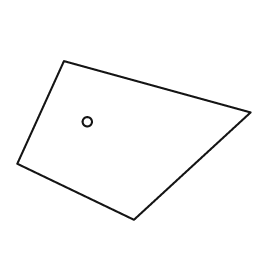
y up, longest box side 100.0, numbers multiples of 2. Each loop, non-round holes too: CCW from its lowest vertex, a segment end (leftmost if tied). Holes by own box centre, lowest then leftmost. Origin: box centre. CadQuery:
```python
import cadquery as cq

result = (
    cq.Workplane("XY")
    .moveTo(0.0, -34.0)
    .lineTo(50.0, 12.0)
    .lineTo(-30.0, 34.0)
    .lineTo(-50.0, -10.0)
    .close()
    .moveTo(-20.0, 8.0)
    .circle(2.0)
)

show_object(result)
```